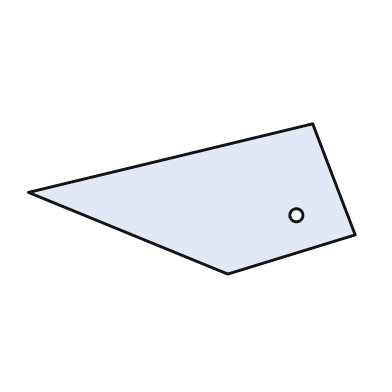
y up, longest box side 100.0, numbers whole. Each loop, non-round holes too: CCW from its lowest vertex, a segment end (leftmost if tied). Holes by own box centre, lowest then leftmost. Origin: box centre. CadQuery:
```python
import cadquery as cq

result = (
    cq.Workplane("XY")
    .moveTo(11.0, -23.0)
    .lineTo(50.0, -11.0)
    .lineTo(37.0, 23.0)
    .lineTo(-50.0, 2.0)
    .close()
    .moveTo(32.0, -5.0)
    .circle(2.0)
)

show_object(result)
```